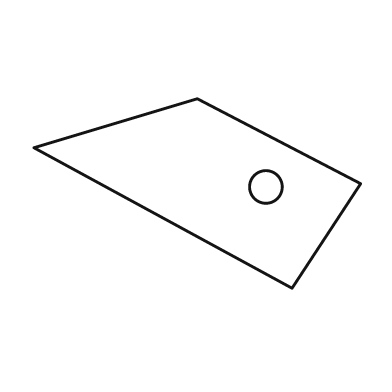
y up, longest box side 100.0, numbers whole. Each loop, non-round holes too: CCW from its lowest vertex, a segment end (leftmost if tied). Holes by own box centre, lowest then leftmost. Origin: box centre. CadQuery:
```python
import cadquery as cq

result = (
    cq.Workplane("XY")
    .moveTo(29.0, -29.0)
    .lineTo(50.0, 3.0)
    .lineTo(0.0, 29.0)
    .lineTo(-50.0, 14.0)
    .close()
    .moveTo(21.0, 2.0)
    .circle(5.0)
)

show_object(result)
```